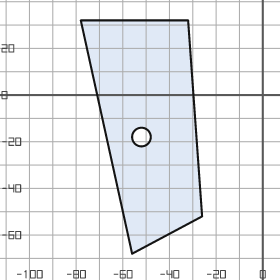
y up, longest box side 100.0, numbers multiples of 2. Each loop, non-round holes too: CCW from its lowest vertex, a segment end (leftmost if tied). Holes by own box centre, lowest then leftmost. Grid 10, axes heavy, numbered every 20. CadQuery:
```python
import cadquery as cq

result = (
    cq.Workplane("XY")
    .moveTo(-56.0, -68.0)
    .lineTo(-26.0, -52.0)
    .lineTo(-32.0, 32.0)
    .lineTo(-78.0, 32.0)
    .close()
    .moveTo(-52.0, -18.0)
    .circle(4.0)
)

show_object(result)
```